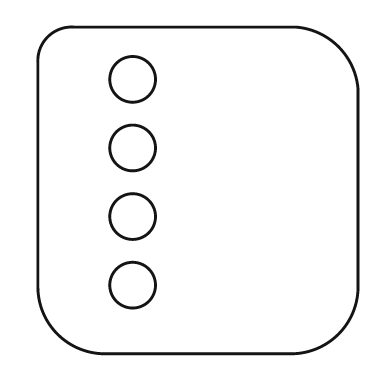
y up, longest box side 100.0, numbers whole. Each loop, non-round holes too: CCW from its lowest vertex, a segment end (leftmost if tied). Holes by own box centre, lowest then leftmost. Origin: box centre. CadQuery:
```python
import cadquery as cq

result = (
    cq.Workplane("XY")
    .moveTo(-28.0, -50.0)
    .lineTo(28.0, -50.0)
    .threePointArc((43.0, -44.0), (49.0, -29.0))
    .lineTo(49.0, 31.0)
    .threePointArc((43.0, 44.0), (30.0, 50.0))
    .lineTo(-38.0, 50.0)
    .threePointArc((-46.0, 47.0), (-49.0, 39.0))
    .lineTo(-49.0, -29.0)
    .threePointArc((-43.0, -44.0), (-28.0, -50.0))
    .close()
    .moveTo(-20.0, -29.0)
    .circle(7.0)
    .moveTo(-20.0, -8.0)
    .circle(7.0)
    .moveTo(-20.0, 13.0)
    .circle(7.0)
    .moveTo(-20.0, 34.0)
    .circle(7.0)
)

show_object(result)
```